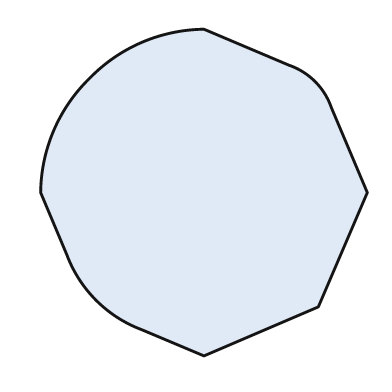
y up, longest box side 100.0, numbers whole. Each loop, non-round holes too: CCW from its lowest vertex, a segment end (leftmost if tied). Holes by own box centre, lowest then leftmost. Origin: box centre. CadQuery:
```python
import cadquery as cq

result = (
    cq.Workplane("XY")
    .moveTo(0.0, -50.0)
    .lineTo(35.0, -35.0)
    .lineTo(50.0, 0.0)
    .lineTo(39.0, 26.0)
    .threePointArc((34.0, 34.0), (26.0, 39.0))
    .lineTo(0.0, 50.0)
    .threePointArc((-19.0, 46.0), (-35.0, 35.0))
    .threePointArc((-46.0, 19.0), (-50.0, 0.0))
    .lineTo(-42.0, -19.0)
    .threePointArc((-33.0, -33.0), (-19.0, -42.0))
    .close()
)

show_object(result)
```